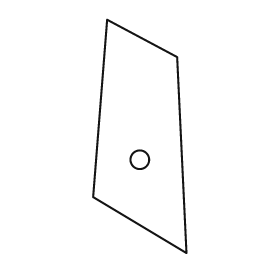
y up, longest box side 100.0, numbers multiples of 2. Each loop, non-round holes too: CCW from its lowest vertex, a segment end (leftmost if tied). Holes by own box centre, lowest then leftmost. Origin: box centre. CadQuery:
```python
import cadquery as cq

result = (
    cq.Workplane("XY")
    .moveTo(20.0, -50.0)
    .lineTo(16.0, 34.0)
    .lineTo(-14.0, 50.0)
    .lineTo(-20.0, -26.0)
    .close()
    .moveTo(0.0, -10.0)
    .circle(4.0)
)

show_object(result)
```